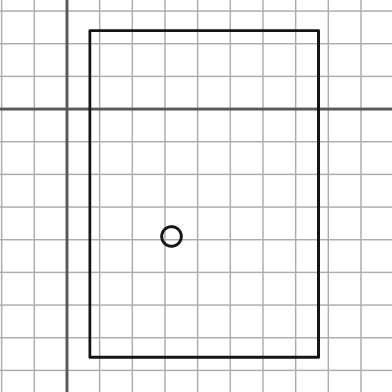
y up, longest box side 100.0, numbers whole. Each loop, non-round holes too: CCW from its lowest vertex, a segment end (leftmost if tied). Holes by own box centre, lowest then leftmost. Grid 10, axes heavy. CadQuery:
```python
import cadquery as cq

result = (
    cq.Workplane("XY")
    .moveTo(7.0, -76.0)
    .lineTo(77.0, -76.0)
    .lineTo(77.0, 24.0)
    .lineTo(7.0, 24.0)
    .close()
    .moveTo(32.0, -39.0)
    .circle(3.0)
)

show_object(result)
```